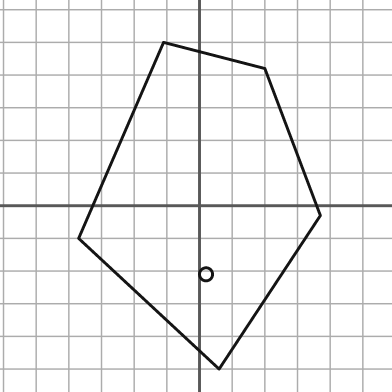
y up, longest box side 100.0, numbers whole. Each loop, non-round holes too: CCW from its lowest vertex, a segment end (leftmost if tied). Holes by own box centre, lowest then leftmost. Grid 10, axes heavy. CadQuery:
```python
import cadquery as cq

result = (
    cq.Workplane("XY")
    .moveTo(6.0, -50.0)
    .lineTo(37.0, -3.0)
    .lineTo(20.0, 42.0)
    .lineTo(-11.0, 50.0)
    .lineTo(-37.0, -10.0)
    .close()
    .moveTo(2.0, -21.0)
    .circle(2.0)
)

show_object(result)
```